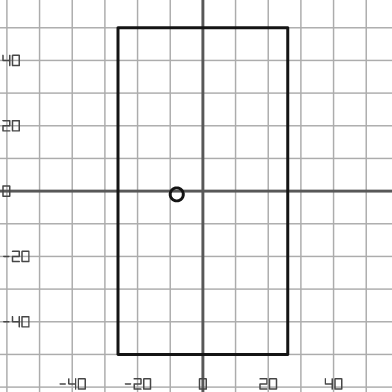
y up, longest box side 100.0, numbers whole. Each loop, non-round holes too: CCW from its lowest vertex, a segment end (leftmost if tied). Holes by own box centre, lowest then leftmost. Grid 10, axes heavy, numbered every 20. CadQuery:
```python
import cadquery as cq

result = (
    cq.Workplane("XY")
    .moveTo(-26.0, -50.0)
    .lineTo(26.0, -50.0)
    .lineTo(26.0, 50.0)
    .lineTo(-26.0, 50.0)
    .close()
    .moveTo(-8.0, -1.0)
    .circle(2.0)
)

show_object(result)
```